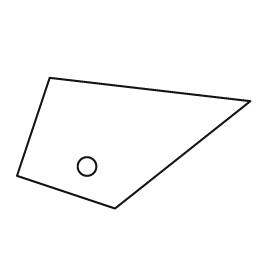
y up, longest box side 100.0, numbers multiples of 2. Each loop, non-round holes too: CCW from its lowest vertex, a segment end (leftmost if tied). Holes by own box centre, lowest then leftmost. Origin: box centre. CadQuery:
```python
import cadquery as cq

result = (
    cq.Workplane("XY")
    .moveTo(-8.0, -28.0)
    .lineTo(50.0, 18.0)
    .lineTo(-36.0, 28.0)
    .lineTo(-50.0, -14.0)
    .close()
    .moveTo(-20.0, -10.0)
    .circle(4.0)
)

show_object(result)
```